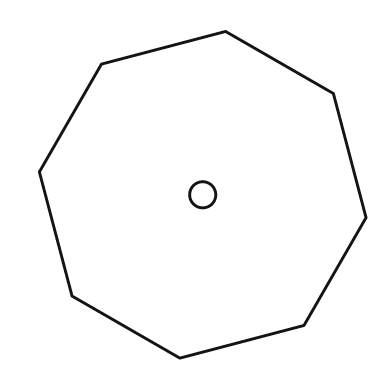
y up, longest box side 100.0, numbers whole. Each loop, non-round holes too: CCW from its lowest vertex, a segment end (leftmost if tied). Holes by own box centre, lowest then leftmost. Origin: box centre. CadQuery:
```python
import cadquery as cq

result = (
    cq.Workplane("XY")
    .moveTo(-7.0, -50.0)
    .lineTo(31.0, -40.0)
    .lineTo(50.0, -7.0)
    .lineTo(40.0, 31.0)
    .lineTo(7.0, 50.0)
    .lineTo(-31.0, 40.0)
    .lineTo(-50.0, 7.0)
    .lineTo(-40.0, -31.0)
    .close()
    .moveTo(0.0, 0.0)
    .circle(4.0)
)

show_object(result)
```